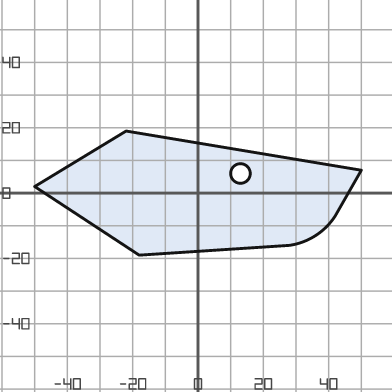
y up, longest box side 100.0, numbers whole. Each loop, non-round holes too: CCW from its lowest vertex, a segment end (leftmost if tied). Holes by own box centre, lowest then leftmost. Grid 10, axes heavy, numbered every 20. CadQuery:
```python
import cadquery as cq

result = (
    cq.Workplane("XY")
    .moveTo(-18.0, -19.0)
    .lineTo(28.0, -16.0)
    .threePointArc((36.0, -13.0), (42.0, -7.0))
    .lineTo(50.0, 7.0)
    .lineTo(-22.0, 19.0)
    .lineTo(-50.0, 2.0)
    .close()
    .moveTo(13.0, 6.0)
    .circle(3.0)
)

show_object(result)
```